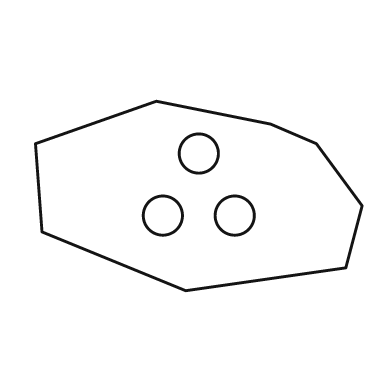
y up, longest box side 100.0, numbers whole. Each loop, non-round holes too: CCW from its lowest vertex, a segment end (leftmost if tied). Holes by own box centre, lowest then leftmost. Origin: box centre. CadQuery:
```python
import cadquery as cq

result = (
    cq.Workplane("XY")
    .moveTo(-4.0, -29.0)
    .lineTo(45.0, -22.0)
    .lineTo(50.0, -3.0)
    .lineTo(36.0, 16.0)
    .lineTo(22.0, 22.0)
    .lineTo(-13.0, 29.0)
    .lineTo(-50.0, 16.0)
    .lineTo(-48.0, -11.0)
    .close()
    .moveTo(-11.0, -6.0)
    .circle(6.0)
    .moveTo(11.0, -6.0)
    .circle(6.0)
    .moveTo(0.0, 13.0)
    .circle(6.0)
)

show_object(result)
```